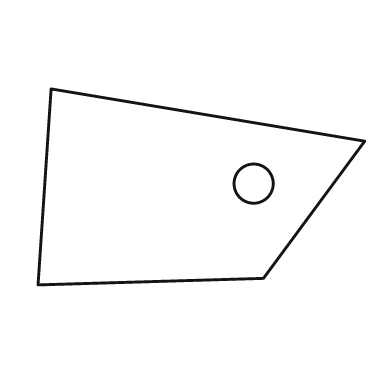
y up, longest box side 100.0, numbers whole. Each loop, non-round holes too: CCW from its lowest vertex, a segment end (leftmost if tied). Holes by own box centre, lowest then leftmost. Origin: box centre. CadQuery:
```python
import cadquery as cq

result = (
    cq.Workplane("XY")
    .moveTo(-50.0, -30.0)
    .lineTo(19.0, -28.0)
    .lineTo(50.0, 14.0)
    .lineTo(-46.0, 30.0)
    .close()
    .moveTo(16.0, 1.0)
    .circle(6.0)
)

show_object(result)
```